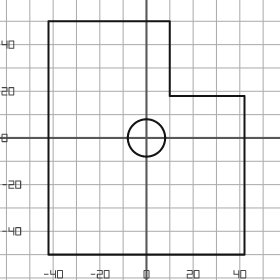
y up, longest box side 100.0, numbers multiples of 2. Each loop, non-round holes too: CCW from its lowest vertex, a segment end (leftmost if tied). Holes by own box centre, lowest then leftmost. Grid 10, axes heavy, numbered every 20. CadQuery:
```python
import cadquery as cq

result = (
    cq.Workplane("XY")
    .moveTo(-42.0, -50.0)
    .lineTo(42.0, -50.0)
    .lineTo(42.0, 18.0)
    .lineTo(10.0, 18.0)
    .lineTo(10.0, 50.0)
    .lineTo(-42.0, 50.0)
    .close()
    .moveTo(0.0, 0.0)
    .circle(8.0)
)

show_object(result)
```